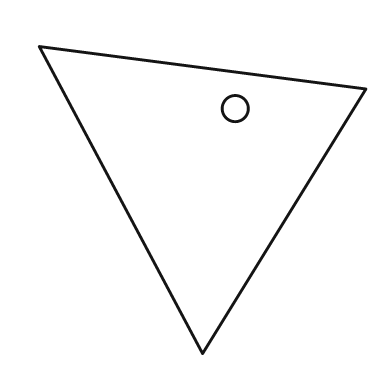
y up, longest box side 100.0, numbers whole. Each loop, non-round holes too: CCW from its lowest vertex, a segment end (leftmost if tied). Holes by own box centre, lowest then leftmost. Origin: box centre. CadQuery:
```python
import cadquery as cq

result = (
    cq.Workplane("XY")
    .moveTo(0.0, -47.0)
    .lineTo(50.0, 34.0)
    .lineTo(-50.0, 47.0)
    .close()
    .moveTo(10.0, 28.0)
    .circle(4.0)
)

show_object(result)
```